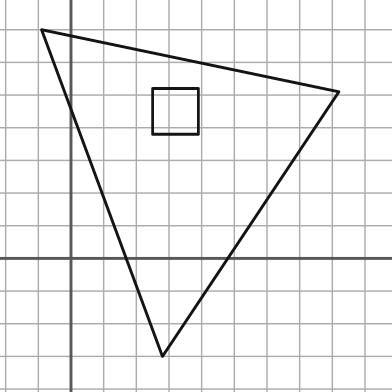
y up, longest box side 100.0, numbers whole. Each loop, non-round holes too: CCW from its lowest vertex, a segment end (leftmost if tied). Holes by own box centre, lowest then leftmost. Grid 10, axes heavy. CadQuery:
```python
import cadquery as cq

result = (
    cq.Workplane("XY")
    .moveTo(28.0, -30.0)
    .lineTo(82.0, 51.0)
    .lineTo(-9.0, 70.0)
    .close()
    .moveTo(25.0, 38.0)
    .lineTo(39.0, 38.0)
    .lineTo(39.0, 52.0)
    .lineTo(25.0, 52.0)
    .close()
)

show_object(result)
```